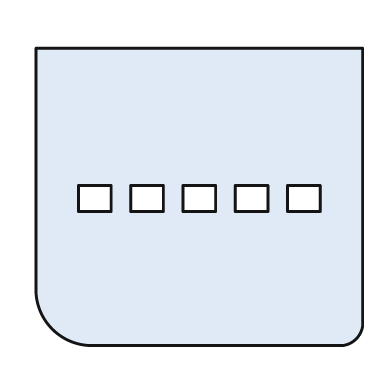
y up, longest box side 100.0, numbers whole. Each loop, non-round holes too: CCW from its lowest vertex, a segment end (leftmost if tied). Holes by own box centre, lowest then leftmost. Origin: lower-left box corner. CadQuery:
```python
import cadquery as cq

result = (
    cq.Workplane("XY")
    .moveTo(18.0, 0.0)
    .lineTo(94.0, 0.0)
    .threePointArc((98.0, 2.0), (100.0, 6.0))
    .lineTo(100.0, 91.0)
    .lineTo(0.0, 91.0)
    .lineTo(0.0, 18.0)
    .threePointArc((5.0, 5.0), (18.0, 0.0))
    .close()
    .moveTo(13.0, 41.0)
    .lineTo(23.0, 41.0)
    .lineTo(23.0, 49.0)
    .lineTo(13.0, 49.0)
    .close()
    .moveTo(29.0, 41.0)
    .lineTo(39.0, 41.0)
    .lineTo(39.0, 49.0)
    .lineTo(29.0, 49.0)
    .close()
    .moveTo(45.0, 41.0)
    .lineTo(55.0, 41.0)
    .lineTo(55.0, 49.0)
    .lineTo(45.0, 49.0)
    .close()
    .moveTo(61.0, 41.0)
    .lineTo(71.0, 41.0)
    .lineTo(71.0, 49.0)
    .lineTo(61.0, 49.0)
    .close()
    .moveTo(77.0, 41.0)
    .lineTo(87.0, 41.0)
    .lineTo(87.0, 49.0)
    .lineTo(77.0, 49.0)
    .close()
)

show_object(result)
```